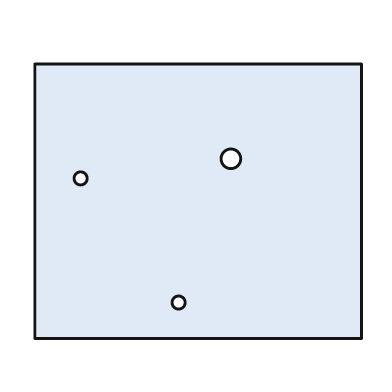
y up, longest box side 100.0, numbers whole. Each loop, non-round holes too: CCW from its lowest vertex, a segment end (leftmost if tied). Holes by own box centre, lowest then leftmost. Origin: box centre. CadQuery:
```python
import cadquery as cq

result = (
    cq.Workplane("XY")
    .moveTo(-50.0, -42.0)
    .lineTo(50.0, -42.0)
    .lineTo(50.0, 42.0)
    .lineTo(-50.0, 42.0)
    .close()
    .moveTo(-6.0, -31.0)
    .circle(2.0)
    .moveTo(-36.0, 7.0)
    .circle(2.0)
    .moveTo(10.0, 13.0)
    .circle(3.0)
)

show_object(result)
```